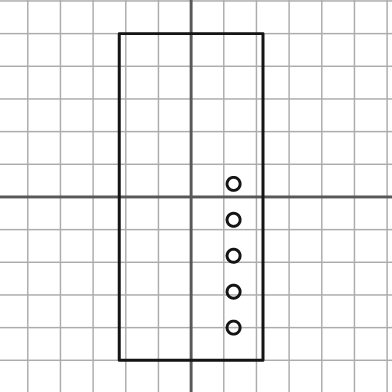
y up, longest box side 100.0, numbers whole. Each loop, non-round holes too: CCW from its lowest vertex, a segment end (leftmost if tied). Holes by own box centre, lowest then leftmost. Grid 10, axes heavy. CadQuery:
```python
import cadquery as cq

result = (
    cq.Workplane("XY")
    .moveTo(-22.0, -50.0)
    .lineTo(22.0, -50.0)
    .lineTo(22.0, 50.0)
    .lineTo(-22.0, 50.0)
    .close()
    .moveTo(13.0, -40.0)
    .circle(2.0)
    .moveTo(13.0, -29.0)
    .circle(2.0)
    .moveTo(13.0, -18.0)
    .circle(2.0)
    .moveTo(13.0, -7.0)
    .circle(2.0)
    .moveTo(13.0, 4.0)
    .circle(2.0)
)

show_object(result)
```